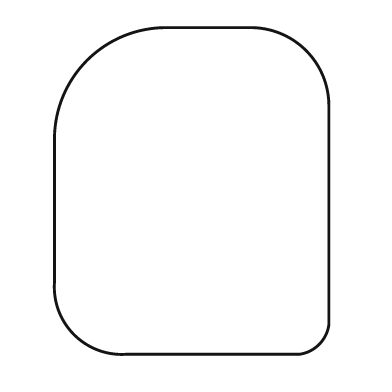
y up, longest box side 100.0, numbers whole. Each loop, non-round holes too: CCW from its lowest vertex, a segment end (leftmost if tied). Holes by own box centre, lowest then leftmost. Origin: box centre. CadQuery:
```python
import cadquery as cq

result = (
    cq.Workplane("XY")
    .moveTo(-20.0, -50.0)
    .lineTo(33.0, -50.0)
    .threePointArc((39.0, -47.0), (42.0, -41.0))
    .lineTo(42.0, 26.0)
    .threePointArc((35.0, 43.0), (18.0, 50.0))
    .lineTo(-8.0, 50.0)
    .threePointArc((-32.0, 40.0), (-42.0, 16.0))
    .lineTo(-42.0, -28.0)
    .threePointArc((-36.0, -44.0), (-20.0, -50.0))
    .close()
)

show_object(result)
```